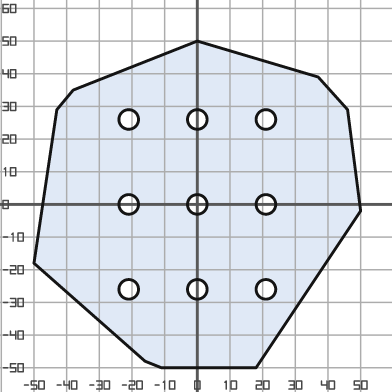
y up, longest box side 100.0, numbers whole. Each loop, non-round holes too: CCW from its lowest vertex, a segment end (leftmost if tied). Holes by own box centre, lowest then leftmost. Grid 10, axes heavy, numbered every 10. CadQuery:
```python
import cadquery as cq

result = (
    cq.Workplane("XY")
    .moveTo(-11.0, -50.0)
    .lineTo(18.0, -50.0)
    .lineTo(50.0, -2.0)
    .lineTo(46.0, 29.0)
    .lineTo(37.0, 39.0)
    .lineTo(0.0, 50.0)
    .lineTo(-38.0, 35.0)
    .lineTo(-43.0, 29.0)
    .lineTo(-50.0, -18.0)
    .lineTo(-16.0, -48.0)
    .close()
    .moveTo(-21.0, -26.0)
    .circle(3.0)
    .moveTo(0.0, -26.0)
    .circle(3.0)
    .moveTo(21.0, -26.0)
    .circle(3.0)
    .moveTo(-21.0, 0.0)
    .circle(3.0)
    .moveTo(0.0, 0.0)
    .circle(3.0)
    .moveTo(21.0, 0.0)
    .circle(3.0)
    .moveTo(-21.0, 26.0)
    .circle(3.0)
    .moveTo(0.0, 26.0)
    .circle(3.0)
    .moveTo(21.0, 26.0)
    .circle(3.0)
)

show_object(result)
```